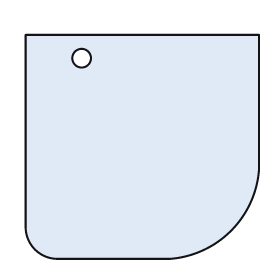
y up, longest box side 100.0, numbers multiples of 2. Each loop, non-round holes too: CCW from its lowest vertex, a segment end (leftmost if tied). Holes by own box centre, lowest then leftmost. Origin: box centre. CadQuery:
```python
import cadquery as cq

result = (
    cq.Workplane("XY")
    .moveTo(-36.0, -48.0)
    .lineTo(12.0, -48.0)
    .threePointArc((38.0, -36.0), (50.0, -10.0))
    .lineTo(50.0, 48.0)
    .lineTo(-50.0, 48.0)
    .lineTo(-50.0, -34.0)
    .threePointArc((-46.0, -44.0), (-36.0, -48.0))
    .close()
    .moveTo(-26.0, 38.0)
    .circle(4.0)
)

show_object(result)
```